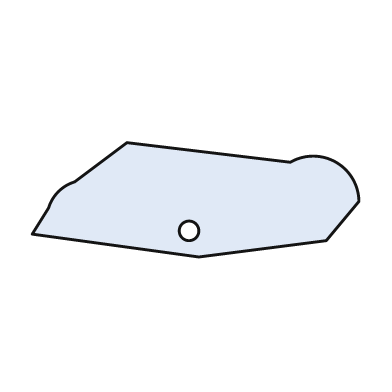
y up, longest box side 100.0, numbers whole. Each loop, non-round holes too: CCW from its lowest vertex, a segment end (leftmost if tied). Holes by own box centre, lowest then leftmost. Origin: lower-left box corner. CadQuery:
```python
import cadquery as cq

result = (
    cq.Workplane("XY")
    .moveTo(51.0, 0.0)
    .lineTo(90.0, 5.0)
    .lineTo(100.0, 17.0)
    .threePointArc((93.0, 29.0), (79.0, 29.0))
    .lineTo(29.0, 35.0)
    .lineTo(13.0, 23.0)
    .threePointArc((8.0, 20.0), (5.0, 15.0))
    .lineTo(0.0, 7.0)
    .close()
    .moveTo(48.0, 8.0)
    .circle(3.0)
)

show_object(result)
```